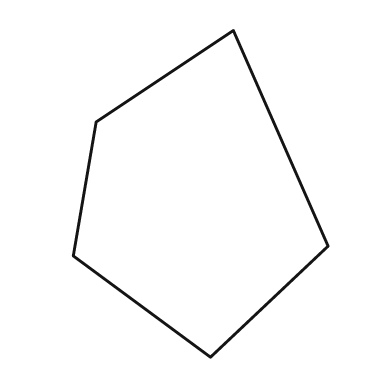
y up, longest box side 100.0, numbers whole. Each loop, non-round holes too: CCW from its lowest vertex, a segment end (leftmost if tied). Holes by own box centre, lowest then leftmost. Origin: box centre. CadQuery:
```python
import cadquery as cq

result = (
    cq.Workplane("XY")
    .moveTo(3.0, -50.0)
    .lineTo(39.0, -16.0)
    .lineTo(10.0, 50.0)
    .lineTo(-32.0, 22.0)
    .lineTo(-39.0, -19.0)
    .close()
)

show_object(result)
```